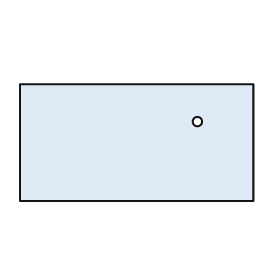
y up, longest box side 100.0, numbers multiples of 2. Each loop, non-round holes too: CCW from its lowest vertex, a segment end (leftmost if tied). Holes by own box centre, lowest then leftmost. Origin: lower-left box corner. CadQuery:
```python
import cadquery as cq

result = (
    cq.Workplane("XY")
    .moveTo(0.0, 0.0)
    .lineTo(100.0, 0.0)
    .lineTo(100.0, 50.0)
    .lineTo(0.0, 50.0)
    .close()
    .moveTo(76.0, 34.0)
    .circle(2.0)
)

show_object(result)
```